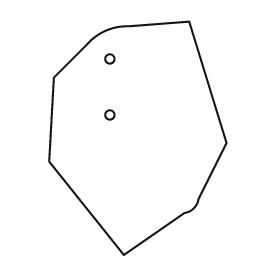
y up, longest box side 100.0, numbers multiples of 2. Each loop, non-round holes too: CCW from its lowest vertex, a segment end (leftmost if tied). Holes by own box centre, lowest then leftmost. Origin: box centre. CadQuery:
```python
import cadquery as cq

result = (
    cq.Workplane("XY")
    .moveTo(-6.0, -50.0)
    .lineTo(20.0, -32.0)
    .threePointArc((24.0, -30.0), (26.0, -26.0))
    .lineTo(38.0, -2.0)
    .lineTo(22.0, 50.0)
    .lineTo(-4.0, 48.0)
    .threePointArc((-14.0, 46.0), (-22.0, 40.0))
    .lineTo(-36.0, 26.0)
    .lineTo(-38.0, -10.0)
    .close()
    .moveTo(-12.0, 10.0)
    .circle(2.0)
    .moveTo(-12.0, 34.0)
    .circle(2.0)
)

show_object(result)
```